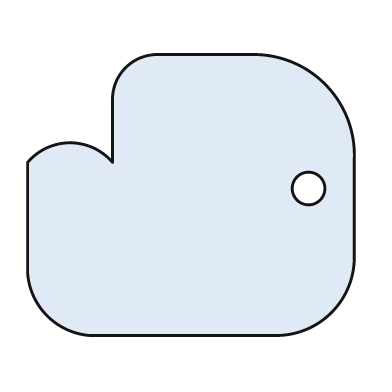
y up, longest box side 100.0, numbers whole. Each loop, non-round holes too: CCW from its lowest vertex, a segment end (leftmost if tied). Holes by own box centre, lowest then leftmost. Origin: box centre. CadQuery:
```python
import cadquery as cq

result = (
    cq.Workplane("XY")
    .moveTo(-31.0, -43.0)
    .lineTo(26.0, -43.0)
    .threePointArc((43.0, -36.0), (50.0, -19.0))
    .lineTo(50.0, 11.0)
    .threePointArc((41.0, 34.0), (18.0, 43.0))
    .lineTo(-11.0, 43.0)
    .threePointArc((-20.0, 39.0), (-24.0, 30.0))
    .lineTo(-24.0, 10.0)
    .threePointArc((-37.0, 16.0), (-50.0, 10.0))
    .lineTo(-50.0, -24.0)
    .threePointArc((-44.0, -37.0), (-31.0, -43.0))
    .close()
    .moveTo(36.0, 2.0)
    .circle(5.0)
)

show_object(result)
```